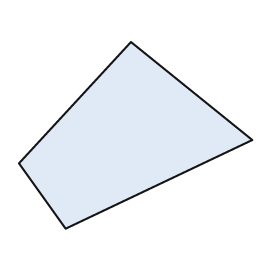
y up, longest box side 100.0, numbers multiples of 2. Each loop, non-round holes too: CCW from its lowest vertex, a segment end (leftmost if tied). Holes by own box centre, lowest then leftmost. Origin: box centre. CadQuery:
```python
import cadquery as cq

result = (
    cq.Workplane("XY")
    .moveTo(-30.0, -40.0)
    .lineTo(50.0, -2.0)
    .lineTo(-2.0, 40.0)
    .lineTo(-50.0, -12.0)
    .close()
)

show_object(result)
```